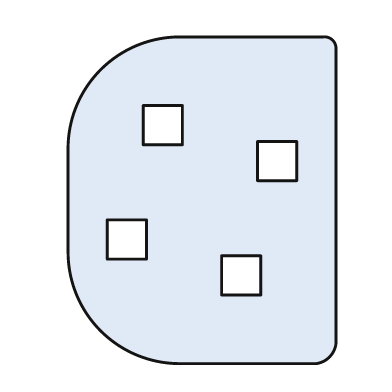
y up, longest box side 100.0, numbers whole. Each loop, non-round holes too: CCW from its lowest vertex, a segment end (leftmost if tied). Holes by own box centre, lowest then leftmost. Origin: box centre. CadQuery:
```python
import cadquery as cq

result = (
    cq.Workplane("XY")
    .moveTo(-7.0, -50.0)
    .lineTo(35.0, -50.0)
    .threePointArc((39.0, -48.0), (41.0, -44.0))
    .lineTo(41.0, 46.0)
    .threePointArc((40.0, 49.0), (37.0, 50.0))
    .lineTo(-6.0, 50.0)
    .threePointArc((-31.0, 40.0), (-41.0, 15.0))
    .lineTo(-41.0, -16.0)
    .threePointArc((-31.0, -40.0), (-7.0, -50.0))
    .close()
    .moveTo(6.0, -29.0)
    .lineTo(18.0, -29.0)
    .lineTo(18.0, -17.0)
    .lineTo(6.0, -17.0)
    .close()
    .moveTo(-29.0, -18.0)
    .lineTo(-17.0, -18.0)
    .lineTo(-17.0, -6.0)
    .lineTo(-29.0, -6.0)
    .close()
    .moveTo(17.0, 6.0)
    .lineTo(29.0, 6.0)
    .lineTo(29.0, 18.0)
    .lineTo(17.0, 18.0)
    .close()
    .moveTo(-18.0, 17.0)
    .lineTo(-6.0, 17.0)
    .lineTo(-6.0, 29.0)
    .lineTo(-18.0, 29.0)
    .close()
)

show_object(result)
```